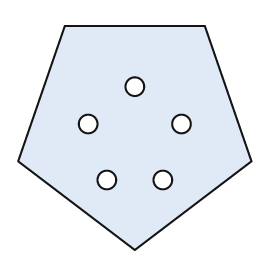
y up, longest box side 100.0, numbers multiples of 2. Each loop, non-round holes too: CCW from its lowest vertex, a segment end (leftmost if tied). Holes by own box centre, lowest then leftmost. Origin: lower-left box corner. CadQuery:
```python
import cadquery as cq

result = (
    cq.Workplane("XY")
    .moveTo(50.0, 0.0)
    .lineTo(100.0, 38.0)
    .lineTo(80.0, 96.0)
    .lineTo(20.0, 96.0)
    .lineTo(0.0, 38.0)
    .close()
    .moveTo(38.0, 30.0)
    .circle(4.0)
    .moveTo(62.0, 30.0)
    .circle(4.0)
    .moveTo(30.0, 54.0)
    .circle(4.0)
    .moveTo(70.0, 54.0)
    .circle(4.0)
    .moveTo(50.0, 70.0)
    .circle(4.0)
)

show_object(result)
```